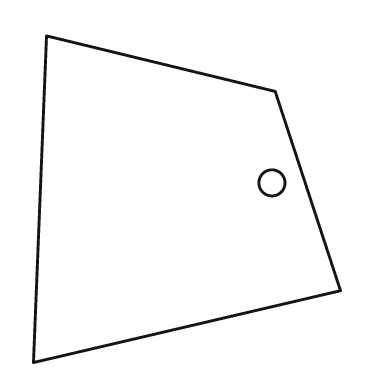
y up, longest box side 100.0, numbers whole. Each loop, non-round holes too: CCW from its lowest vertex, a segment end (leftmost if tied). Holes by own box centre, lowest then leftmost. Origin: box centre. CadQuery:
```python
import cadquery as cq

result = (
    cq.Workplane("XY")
    .moveTo(-47.0, -50.0)
    .lineTo(47.0, -28.0)
    .lineTo(27.0, 33.0)
    .lineTo(-43.0, 50.0)
    .close()
    .moveTo(26.0, 5.0)
    .circle(4.0)
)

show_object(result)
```